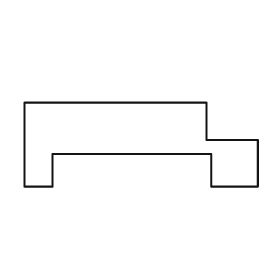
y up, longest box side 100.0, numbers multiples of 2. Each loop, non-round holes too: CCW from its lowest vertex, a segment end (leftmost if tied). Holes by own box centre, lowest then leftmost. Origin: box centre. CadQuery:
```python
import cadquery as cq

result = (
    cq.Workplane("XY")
    .moveTo(-50.0, -18.0)
    .lineTo(-38.0, -18.0)
    .lineTo(-38.0, -4.0)
    .lineTo(30.0, -4.0)
    .lineTo(30.0, -18.0)
    .lineTo(50.0, -18.0)
    .lineTo(50.0, 2.0)
    .lineTo(28.0, 2.0)
    .lineTo(28.0, 18.0)
    .lineTo(-50.0, 18.0)
    .close()
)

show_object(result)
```